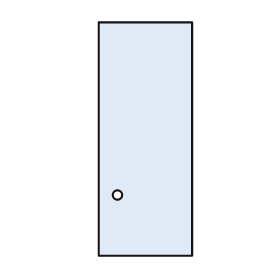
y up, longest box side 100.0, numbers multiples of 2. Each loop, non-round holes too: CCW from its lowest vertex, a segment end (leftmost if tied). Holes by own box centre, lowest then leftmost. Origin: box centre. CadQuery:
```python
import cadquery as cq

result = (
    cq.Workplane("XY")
    .moveTo(-20.0, -50.0)
    .lineTo(20.0, -50.0)
    .lineTo(20.0, 50.0)
    .lineTo(-20.0, 50.0)
    .close()
    .moveTo(-12.0, -24.0)
    .circle(2.0)
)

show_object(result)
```